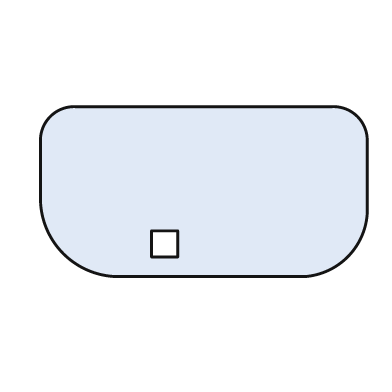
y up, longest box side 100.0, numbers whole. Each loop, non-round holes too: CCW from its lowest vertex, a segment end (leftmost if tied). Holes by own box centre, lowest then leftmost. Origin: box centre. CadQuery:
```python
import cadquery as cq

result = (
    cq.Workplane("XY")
    .moveTo(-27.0, -26.0)
    .lineTo(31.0, -26.0)
    .threePointArc((44.0, -20.0), (50.0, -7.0))
    .lineTo(50.0, 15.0)
    .threePointArc((47.0, 23.0), (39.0, 26.0))
    .lineTo(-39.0, 26.0)
    .threePointArc((-47.0, 23.0), (-50.0, 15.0))
    .lineTo(-50.0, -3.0)
    .threePointArc((-43.0, -19.0), (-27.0, -26.0))
    .close()
    .moveTo(-16.0, -20.0)
    .lineTo(-8.0, -20.0)
    .lineTo(-8.0, -12.0)
    .lineTo(-16.0, -12.0)
    .close()
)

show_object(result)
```